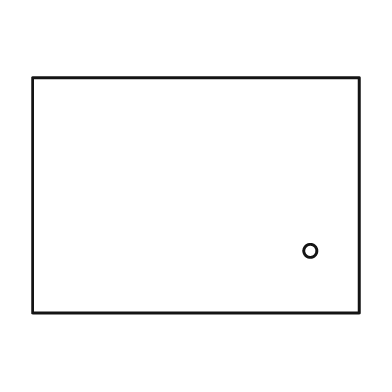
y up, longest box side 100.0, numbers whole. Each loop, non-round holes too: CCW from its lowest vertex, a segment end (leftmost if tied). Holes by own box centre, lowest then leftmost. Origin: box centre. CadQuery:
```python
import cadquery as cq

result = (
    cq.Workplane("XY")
    .moveTo(-50.0, -36.0)
    .lineTo(50.0, -36.0)
    .lineTo(50.0, 36.0)
    .lineTo(-50.0, 36.0)
    .close()
    .moveTo(35.0, -17.0)
    .circle(2.0)
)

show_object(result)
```